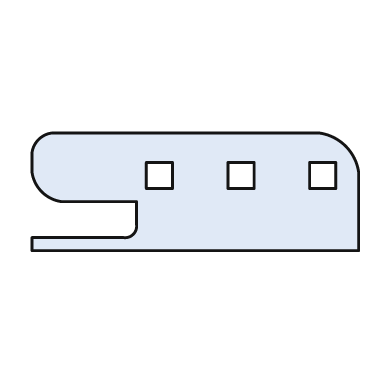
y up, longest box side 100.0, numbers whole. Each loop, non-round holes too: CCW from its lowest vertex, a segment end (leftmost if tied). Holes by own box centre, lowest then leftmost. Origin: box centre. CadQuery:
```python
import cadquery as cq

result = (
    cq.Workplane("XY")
    .moveTo(-50.0, -18.0)
    .lineTo(50.0, -18.0)
    .lineTo(50.0, 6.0)
    .threePointArc((46.0, 14.0), (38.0, 18.0))
    .lineTo(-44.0, 18.0)
    .threePointArc((-48.0, 16.0), (-50.0, 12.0))
    .lineTo(-50.0, 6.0)
    .threePointArc((-47.0, 0.0), (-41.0, -3.0))
    .lineTo(-18.0, -3.0)
    .lineTo(-18.0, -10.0)
    .threePointArc((-19.0, -13.0), (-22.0, -14.0))
    .lineTo(-50.0, -14.0)
    .close()
    .moveTo(-15.0, 1.0)
    .lineTo(-7.0, 1.0)
    .lineTo(-7.0, 9.0)
    .lineTo(-15.0, 9.0)
    .close()
    .moveTo(10.0, 1.0)
    .lineTo(18.0, 1.0)
    .lineTo(18.0, 9.0)
    .lineTo(10.0, 9.0)
    .close()
    .moveTo(35.0, 1.0)
    .lineTo(43.0, 1.0)
    .lineTo(43.0, 9.0)
    .lineTo(35.0, 9.0)
    .close()
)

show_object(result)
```